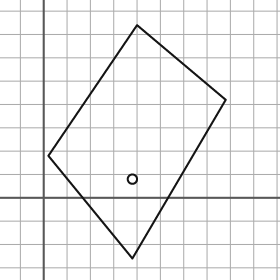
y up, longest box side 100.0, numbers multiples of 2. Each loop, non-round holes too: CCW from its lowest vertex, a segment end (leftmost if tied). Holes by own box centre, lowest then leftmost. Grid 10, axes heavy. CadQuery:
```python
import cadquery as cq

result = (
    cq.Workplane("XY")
    .moveTo(38.0, -26.0)
    .lineTo(78.0, 42.0)
    .lineTo(40.0, 74.0)
    .lineTo(2.0, 18.0)
    .close()
    .moveTo(38.0, 8.0)
    .circle(2.0)
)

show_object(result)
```